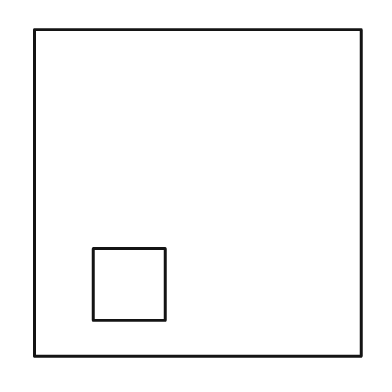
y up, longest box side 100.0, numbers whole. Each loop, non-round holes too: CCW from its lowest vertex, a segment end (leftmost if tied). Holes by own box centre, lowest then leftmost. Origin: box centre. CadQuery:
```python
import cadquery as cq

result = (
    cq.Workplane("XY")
    .moveTo(-50.0, -50.0)
    .lineTo(50.0, -50.0)
    .lineTo(50.0, 50.0)
    .lineTo(-50.0, 50.0)
    .close()
    .moveTo(-32.0, -39.0)
    .lineTo(-10.0, -39.0)
    .lineTo(-10.0, -17.0)
    .lineTo(-32.0, -17.0)
    .close()
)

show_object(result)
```